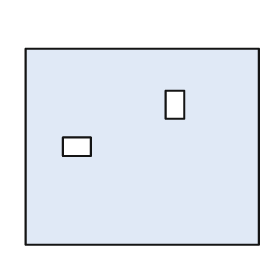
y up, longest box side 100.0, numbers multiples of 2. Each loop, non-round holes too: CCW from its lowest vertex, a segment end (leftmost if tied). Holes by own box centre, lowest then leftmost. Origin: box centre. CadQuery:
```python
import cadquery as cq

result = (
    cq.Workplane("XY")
    .moveTo(-50.0, -42.0)
    .lineTo(50.0, -42.0)
    .lineTo(50.0, 42.0)
    .lineTo(-50.0, 42.0)
    .close()
    .moveTo(-34.0, -4.0)
    .lineTo(-22.0, -4.0)
    .lineTo(-22.0, 4.0)
    .lineTo(-34.0, 4.0)
    .close()
    .moveTo(10.0, 12.0)
    .lineTo(18.0, 12.0)
    .lineTo(18.0, 24.0)
    .lineTo(10.0, 24.0)
    .close()
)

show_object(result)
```